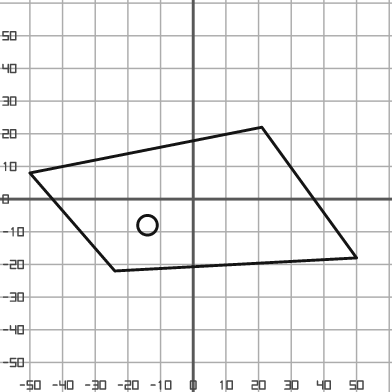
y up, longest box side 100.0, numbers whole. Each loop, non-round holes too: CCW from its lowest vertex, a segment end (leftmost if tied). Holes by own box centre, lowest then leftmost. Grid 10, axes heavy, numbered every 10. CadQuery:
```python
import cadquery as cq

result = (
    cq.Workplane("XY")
    .moveTo(-24.0, -22.0)
    .lineTo(50.0, -18.0)
    .lineTo(21.0, 22.0)
    .lineTo(-50.0, 8.0)
    .close()
    .moveTo(-14.0, -8.0)
    .circle(3.0)
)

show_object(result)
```